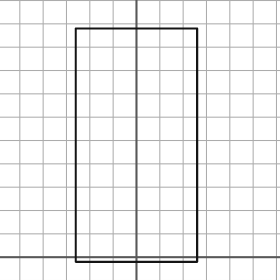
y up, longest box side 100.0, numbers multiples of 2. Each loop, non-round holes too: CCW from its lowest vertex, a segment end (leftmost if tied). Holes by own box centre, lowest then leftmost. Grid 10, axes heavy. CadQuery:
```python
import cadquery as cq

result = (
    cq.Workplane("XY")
    .moveTo(-26.0, -2.0)
    .lineTo(26.0, -2.0)
    .lineTo(26.0, 98.0)
    .lineTo(-26.0, 98.0)
    .close()
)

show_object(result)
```